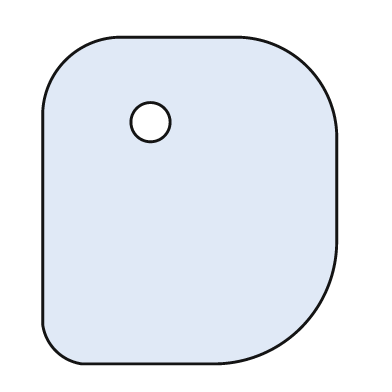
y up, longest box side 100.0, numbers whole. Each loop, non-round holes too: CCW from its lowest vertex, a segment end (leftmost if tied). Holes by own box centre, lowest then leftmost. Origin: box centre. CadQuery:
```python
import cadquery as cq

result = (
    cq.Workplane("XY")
    .moveTo(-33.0, -50.0)
    .lineTo(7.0, -50.0)
    .threePointArc((34.0, -39.0), (45.0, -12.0))
    .lineTo(45.0, 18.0)
    .threePointArc((36.0, 41.0), (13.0, 50.0))
    .lineTo(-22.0, 50.0)
    .threePointArc((-38.0, 43.0), (-45.0, 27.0))
    .lineTo(-45.0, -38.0)
    .threePointArc((-41.0, -46.0), (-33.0, -50.0))
    .close()
    .moveTo(-12.0, 24.0)
    .circle(6.0)
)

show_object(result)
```